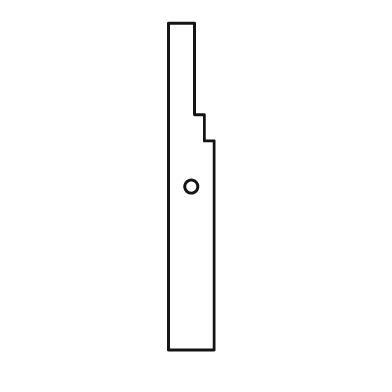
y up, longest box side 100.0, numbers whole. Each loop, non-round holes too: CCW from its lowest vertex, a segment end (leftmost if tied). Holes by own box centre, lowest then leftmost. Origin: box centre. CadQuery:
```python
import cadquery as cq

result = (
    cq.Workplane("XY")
    .moveTo(-7.0, -50.0)
    .lineTo(7.0, -50.0)
    .lineTo(7.0, 14.0)
    .lineTo(4.0, 14.0)
    .lineTo(4.0, 22.0)
    .lineTo(1.0, 22.0)
    .lineTo(1.0, 50.0)
    .lineTo(-7.0, 50.0)
    .close()
    .moveTo(0.0, 0.0)
    .circle(2.0)
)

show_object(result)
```